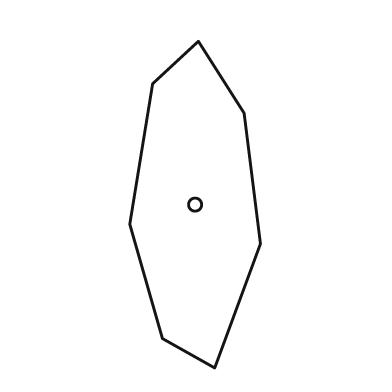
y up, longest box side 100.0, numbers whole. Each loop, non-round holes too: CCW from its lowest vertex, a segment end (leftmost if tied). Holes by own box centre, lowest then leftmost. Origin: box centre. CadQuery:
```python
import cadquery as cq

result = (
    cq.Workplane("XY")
    .moveTo(6.0, -50.0)
    .lineTo(20.0, -12.0)
    .lineTo(15.0, 28.0)
    .lineTo(1.0, 50.0)
    .lineTo(-13.0, 37.0)
    .lineTo(-20.0, -6.0)
    .lineTo(-10.0, -41.0)
    .close()
    .moveTo(0.0, 0.0)
    .circle(2.0)
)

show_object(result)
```